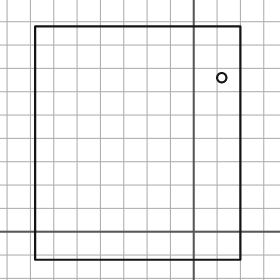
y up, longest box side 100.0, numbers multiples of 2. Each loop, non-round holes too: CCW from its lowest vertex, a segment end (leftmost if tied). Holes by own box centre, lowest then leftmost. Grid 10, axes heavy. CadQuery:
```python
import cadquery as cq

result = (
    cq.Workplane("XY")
    .moveTo(-68.0, -12.0)
    .lineTo(20.0, -12.0)
    .lineTo(20.0, 88.0)
    .lineTo(-68.0, 88.0)
    .close()
    .moveTo(12.0, 66.0)
    .circle(2.0)
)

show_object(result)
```